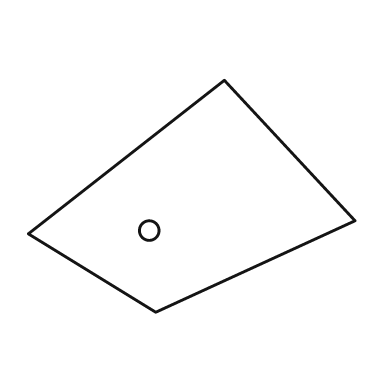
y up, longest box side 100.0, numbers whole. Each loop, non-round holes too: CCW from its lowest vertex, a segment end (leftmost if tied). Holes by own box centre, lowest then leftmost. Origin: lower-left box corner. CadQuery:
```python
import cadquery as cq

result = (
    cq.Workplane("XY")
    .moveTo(39.0, 0.0)
    .lineTo(100.0, 28.0)
    .lineTo(60.0, 71.0)
    .lineTo(0.0, 24.0)
    .close()
    .moveTo(37.0, 25.0)
    .circle(3.0)
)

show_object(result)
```